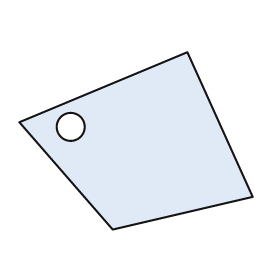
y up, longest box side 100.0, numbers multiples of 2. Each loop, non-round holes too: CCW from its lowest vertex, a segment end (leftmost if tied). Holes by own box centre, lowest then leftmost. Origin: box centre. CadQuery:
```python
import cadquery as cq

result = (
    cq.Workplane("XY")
    .moveTo(-10.0, -38.0)
    .lineTo(50.0, -24.0)
    .lineTo(22.0, 38.0)
    .lineTo(-50.0, 8.0)
    .close()
    .moveTo(-28.0, 6.0)
    .circle(6.0)
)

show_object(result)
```